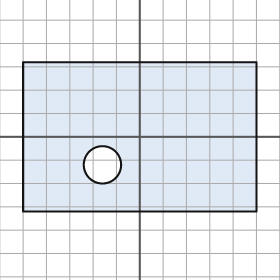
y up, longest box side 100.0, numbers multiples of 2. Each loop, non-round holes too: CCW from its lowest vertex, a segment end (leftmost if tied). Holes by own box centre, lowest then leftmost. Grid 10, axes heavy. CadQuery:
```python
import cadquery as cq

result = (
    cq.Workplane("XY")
    .moveTo(-50.0, -32.0)
    .lineTo(50.0, -32.0)
    .lineTo(50.0, 32.0)
    .lineTo(-50.0, 32.0)
    .close()
    .moveTo(-16.0, -12.0)
    .circle(8.0)
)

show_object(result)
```